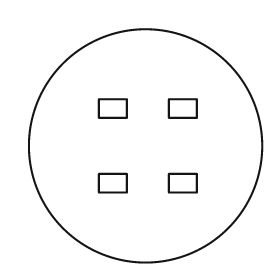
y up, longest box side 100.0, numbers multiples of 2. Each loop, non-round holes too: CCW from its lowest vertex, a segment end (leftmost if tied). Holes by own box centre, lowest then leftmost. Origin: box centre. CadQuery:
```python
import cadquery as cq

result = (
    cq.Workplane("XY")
    .moveTo(0.0, 0.0)
    .circle(50.0)
    .moveTo(-20.0, -20.0)
    .lineTo(-8.0, -20.0)
    .lineTo(-8.0, -12.0)
    .lineTo(-20.0, -12.0)
    .close()
    .moveTo(10.0, -20.0)
    .lineTo(22.0, -20.0)
    .lineTo(22.0, -12.0)
    .lineTo(10.0, -12.0)
    .close()
    .moveTo(-20.0, 12.0)
    .lineTo(-8.0, 12.0)
    .lineTo(-8.0, 20.0)
    .lineTo(-20.0, 20.0)
    .close()
    .moveTo(10.0, 12.0)
    .lineTo(22.0, 12.0)
    .lineTo(22.0, 20.0)
    .lineTo(10.0, 20.0)
    .close()
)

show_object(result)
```